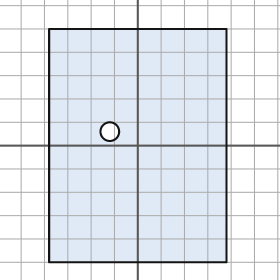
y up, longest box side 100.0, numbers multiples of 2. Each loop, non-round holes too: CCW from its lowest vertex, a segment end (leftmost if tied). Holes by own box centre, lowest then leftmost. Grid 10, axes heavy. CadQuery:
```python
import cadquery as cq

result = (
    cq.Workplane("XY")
    .moveTo(-38.0, -50.0)
    .lineTo(38.0, -50.0)
    .lineTo(38.0, 50.0)
    .lineTo(-38.0, 50.0)
    .close()
    .moveTo(-12.0, 6.0)
    .circle(4.0)
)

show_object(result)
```